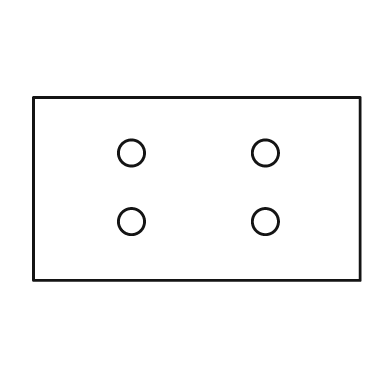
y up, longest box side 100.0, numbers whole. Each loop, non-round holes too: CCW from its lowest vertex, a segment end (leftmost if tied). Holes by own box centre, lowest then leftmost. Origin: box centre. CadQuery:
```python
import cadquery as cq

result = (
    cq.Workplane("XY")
    .moveTo(-50.0, -28.0)
    .lineTo(50.0, -28.0)
    .lineTo(50.0, 28.0)
    .lineTo(-50.0, 28.0)
    .close()
    .moveTo(-20.0, -10.0)
    .circle(4.0)
    .moveTo(21.0, -10.0)
    .circle(4.0)
    .moveTo(-20.0, 11.0)
    .circle(4.0)
    .moveTo(21.0, 11.0)
    .circle(4.0)
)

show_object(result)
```